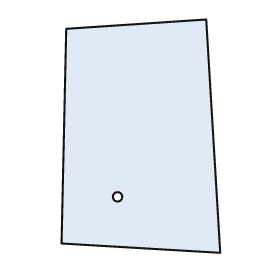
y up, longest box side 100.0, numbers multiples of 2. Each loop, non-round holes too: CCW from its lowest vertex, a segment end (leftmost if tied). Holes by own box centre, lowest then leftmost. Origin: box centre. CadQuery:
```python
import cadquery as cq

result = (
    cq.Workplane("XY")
    .moveTo(34.0, -50.0)
    .lineTo(28.0, 50.0)
    .lineTo(-32.0, 46.0)
    .lineTo(-34.0, -46.0)
    .close()
    .moveTo(-10.0, -26.0)
    .circle(2.0)
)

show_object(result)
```